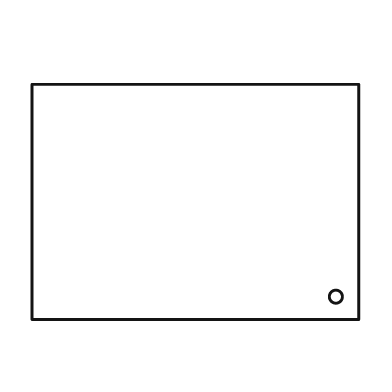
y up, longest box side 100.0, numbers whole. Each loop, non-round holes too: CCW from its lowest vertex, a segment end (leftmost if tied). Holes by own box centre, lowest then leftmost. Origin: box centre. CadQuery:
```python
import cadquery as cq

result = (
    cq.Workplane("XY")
    .moveTo(-50.0, -36.0)
    .lineTo(50.0, -36.0)
    .lineTo(50.0, 36.0)
    .lineTo(-50.0, 36.0)
    .close()
    .moveTo(43.0, -29.0)
    .circle(2.0)
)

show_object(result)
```